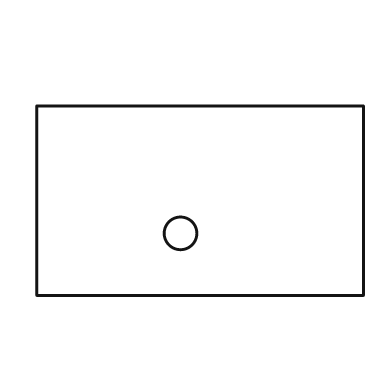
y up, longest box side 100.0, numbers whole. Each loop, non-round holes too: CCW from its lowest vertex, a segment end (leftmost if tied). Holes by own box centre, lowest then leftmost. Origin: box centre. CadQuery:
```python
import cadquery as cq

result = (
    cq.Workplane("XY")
    .moveTo(-50.0, -29.0)
    .lineTo(50.0, -29.0)
    .lineTo(50.0, 29.0)
    .lineTo(-50.0, 29.0)
    .close()
    .moveTo(-6.0, -10.0)
    .circle(5.0)
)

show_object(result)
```